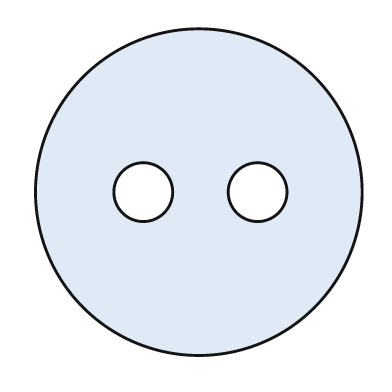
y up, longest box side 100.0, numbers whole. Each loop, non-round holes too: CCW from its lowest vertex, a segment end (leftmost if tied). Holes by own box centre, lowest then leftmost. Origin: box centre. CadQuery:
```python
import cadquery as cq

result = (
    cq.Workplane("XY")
    .moveTo(0.0, 0.0)
    .circle(50.0)
    .moveTo(-17.0, 0.0)
    .circle(9.0)
    .moveTo(18.0, 0.0)
    .circle(9.0)
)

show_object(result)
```